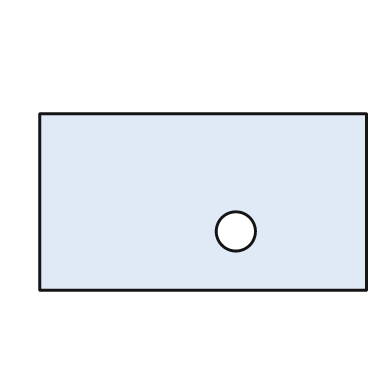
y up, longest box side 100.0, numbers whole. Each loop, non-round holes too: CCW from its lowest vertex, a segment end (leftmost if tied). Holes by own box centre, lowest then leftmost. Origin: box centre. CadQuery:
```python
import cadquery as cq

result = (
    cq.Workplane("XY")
    .moveTo(-50.0, -27.0)
    .lineTo(50.0, -27.0)
    .lineTo(50.0, 27.0)
    .lineTo(-50.0, 27.0)
    .close()
    .moveTo(10.0, -9.0)
    .circle(6.0)
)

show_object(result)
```